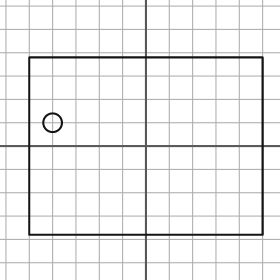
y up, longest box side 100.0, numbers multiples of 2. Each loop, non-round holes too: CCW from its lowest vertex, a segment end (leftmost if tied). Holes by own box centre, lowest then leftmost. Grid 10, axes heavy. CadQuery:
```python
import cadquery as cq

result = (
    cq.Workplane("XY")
    .moveTo(-50.0, -38.0)
    .lineTo(50.0, -38.0)
    .lineTo(50.0, 38.0)
    .lineTo(-50.0, 38.0)
    .close()
    .moveTo(-40.0, 10.0)
    .circle(4.0)
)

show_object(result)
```